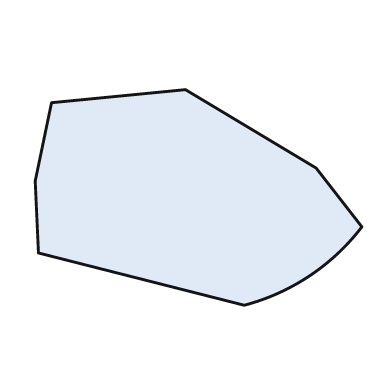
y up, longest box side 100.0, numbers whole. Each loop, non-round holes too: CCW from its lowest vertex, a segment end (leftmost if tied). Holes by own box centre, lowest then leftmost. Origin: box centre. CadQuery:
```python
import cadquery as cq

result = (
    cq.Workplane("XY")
    .moveTo(14.0, -33.0)
    .threePointArc((34.0, -24.0), (50.0, -9.0))
    .lineTo(36.0, 9.0)
    .lineTo(-4.0, 33.0)
    .lineTo(-45.0, 29.0)
    .lineTo(-50.0, 5.0)
    .lineTo(-49.0, -17.0)
    .close()
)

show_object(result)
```